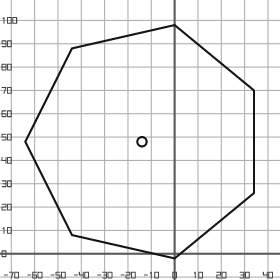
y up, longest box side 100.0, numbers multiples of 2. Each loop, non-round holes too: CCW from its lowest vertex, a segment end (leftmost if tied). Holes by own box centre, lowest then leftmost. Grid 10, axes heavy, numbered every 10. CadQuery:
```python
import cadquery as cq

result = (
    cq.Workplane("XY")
    .moveTo(0.0, -2.0)
    .lineTo(34.0, 26.0)
    .lineTo(34.0, 70.0)
    .lineTo(0.0, 98.0)
    .lineTo(-44.0, 88.0)
    .lineTo(-64.0, 48.0)
    .lineTo(-44.0, 8.0)
    .close()
    .moveTo(-14.0, 48.0)
    .circle(2.0)
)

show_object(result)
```